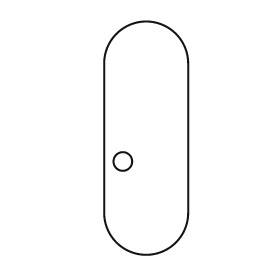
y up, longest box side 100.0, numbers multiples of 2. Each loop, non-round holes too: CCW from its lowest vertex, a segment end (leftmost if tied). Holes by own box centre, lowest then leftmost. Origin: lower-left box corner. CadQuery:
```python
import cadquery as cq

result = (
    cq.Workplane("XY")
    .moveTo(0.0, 18.0)
    .threePointArc((18.0, 0.0), (36.0, 18.0))
    .lineTo(36.0, 82.0)
    .threePointArc((18.0, 100.0), (0.0, 82.0))
    .close()
    .moveTo(8.0, 40.0)
    .circle(4.0)
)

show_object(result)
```